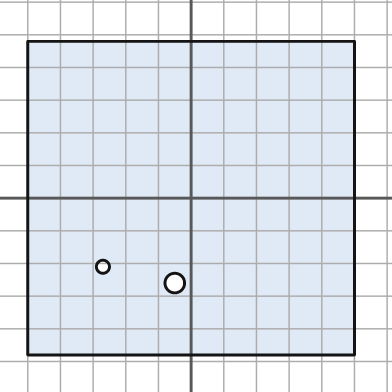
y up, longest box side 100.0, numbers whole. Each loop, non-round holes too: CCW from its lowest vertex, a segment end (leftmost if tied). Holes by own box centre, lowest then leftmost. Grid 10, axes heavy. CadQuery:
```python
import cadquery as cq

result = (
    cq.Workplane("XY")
    .moveTo(-50.0, -48.0)
    .lineTo(50.0, -48.0)
    .lineTo(50.0, 48.0)
    .lineTo(-50.0, 48.0)
    .close()
    .moveTo(-5.0, -26.0)
    .circle(3.0)
    .moveTo(-27.0, -21.0)
    .circle(2.0)
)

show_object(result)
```